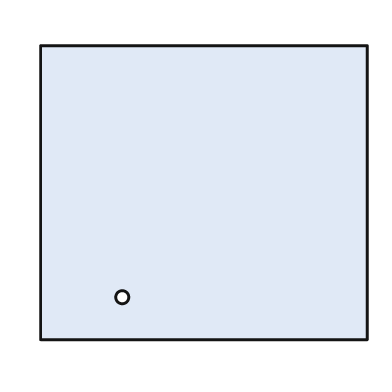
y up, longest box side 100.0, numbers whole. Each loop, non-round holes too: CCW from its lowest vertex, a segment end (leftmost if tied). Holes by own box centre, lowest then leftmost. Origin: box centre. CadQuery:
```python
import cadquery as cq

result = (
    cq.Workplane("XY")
    .moveTo(-50.0, -45.0)
    .lineTo(50.0, -45.0)
    .lineTo(50.0, 45.0)
    .lineTo(-50.0, 45.0)
    .close()
    .moveTo(-25.0, -32.0)
    .circle(2.0)
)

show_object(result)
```